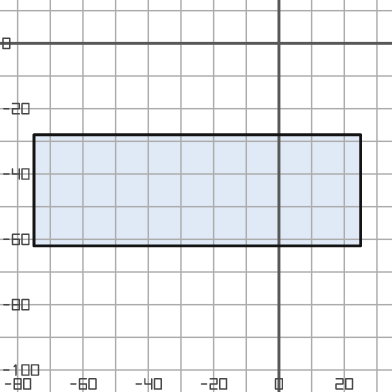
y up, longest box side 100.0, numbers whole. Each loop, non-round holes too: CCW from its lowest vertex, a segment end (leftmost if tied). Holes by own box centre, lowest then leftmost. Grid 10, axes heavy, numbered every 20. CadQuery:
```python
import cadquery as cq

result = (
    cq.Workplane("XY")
    .moveTo(-75.0, -62.0)
    .lineTo(25.0, -62.0)
    .lineTo(25.0, -28.0)
    .lineTo(-75.0, -28.0)
    .close()
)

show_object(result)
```